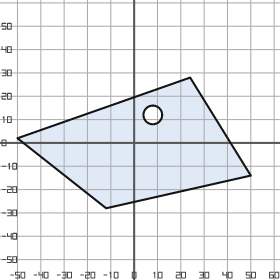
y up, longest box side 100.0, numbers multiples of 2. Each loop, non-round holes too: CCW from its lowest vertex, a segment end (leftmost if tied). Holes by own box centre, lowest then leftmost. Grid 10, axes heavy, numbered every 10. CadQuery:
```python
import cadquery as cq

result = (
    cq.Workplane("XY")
    .moveTo(-12.0, -28.0)
    .lineTo(50.0, -14.0)
    .lineTo(24.0, 28.0)
    .lineTo(-50.0, 2.0)
    .close()
    .moveTo(8.0, 12.0)
    .circle(4.0)
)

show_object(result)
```